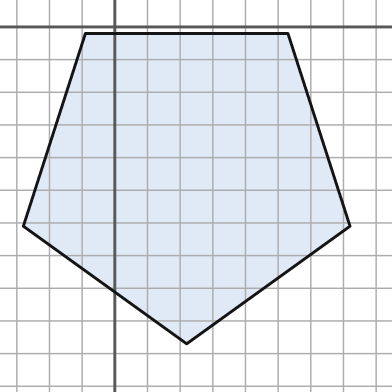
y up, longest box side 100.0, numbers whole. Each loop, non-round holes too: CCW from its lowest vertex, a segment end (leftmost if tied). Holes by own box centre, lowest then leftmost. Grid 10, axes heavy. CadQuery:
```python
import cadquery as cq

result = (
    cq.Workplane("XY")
    .moveTo(22.0, -97.0)
    .lineTo(72.0, -61.0)
    .lineTo(53.0, -2.0)
    .lineTo(-9.0, -2.0)
    .lineTo(-28.0, -61.0)
    .close()
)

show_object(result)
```